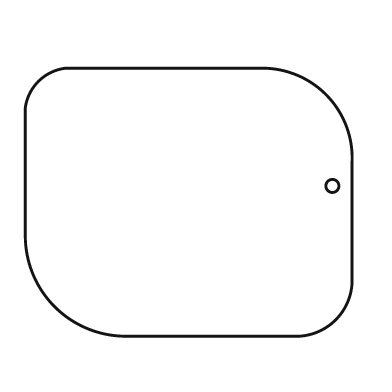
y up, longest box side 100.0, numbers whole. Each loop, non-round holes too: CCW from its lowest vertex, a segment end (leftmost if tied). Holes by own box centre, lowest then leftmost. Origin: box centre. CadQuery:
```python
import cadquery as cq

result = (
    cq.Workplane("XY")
    .moveTo(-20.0, -41.0)
    .lineTo(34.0, -41.0)
    .threePointArc((45.0, -36.0), (50.0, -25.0))
    .lineTo(50.0, 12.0)
    .threePointArc((42.0, 33.0), (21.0, 41.0))
    .lineTo(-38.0, 41.0)
    .threePointArc((-46.0, 37.0), (-50.0, 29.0))
    .lineTo(-50.0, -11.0)
    .threePointArc((-41.0, -32.0), (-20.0, -41.0))
    .close()
    .moveTo(44.0, 5.0)
    .circle(2.0)
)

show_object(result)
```